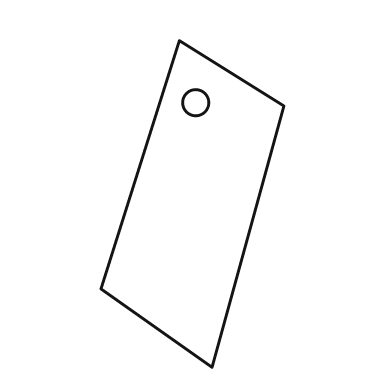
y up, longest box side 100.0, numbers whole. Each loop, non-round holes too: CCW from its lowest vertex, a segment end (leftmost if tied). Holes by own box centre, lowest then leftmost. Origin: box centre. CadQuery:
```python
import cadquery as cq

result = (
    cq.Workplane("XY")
    .moveTo(6.0, -50.0)
    .lineTo(28.0, 30.0)
    .lineTo(-4.0, 50.0)
    .lineTo(-28.0, -26.0)
    .close()
    .moveTo(1.0, 31.0)
    .circle(4.0)
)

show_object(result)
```